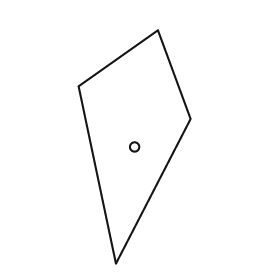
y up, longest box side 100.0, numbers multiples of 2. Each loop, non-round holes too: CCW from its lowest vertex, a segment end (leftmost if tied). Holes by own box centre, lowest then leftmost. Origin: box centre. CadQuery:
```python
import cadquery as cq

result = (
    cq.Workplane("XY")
    .moveTo(-8.0, -50.0)
    .lineTo(24.0, 12.0)
    .lineTo(10.0, 50.0)
    .lineTo(-24.0, 26.0)
    .close()
    .moveTo(0.0, 0.0)
    .circle(2.0)
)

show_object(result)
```